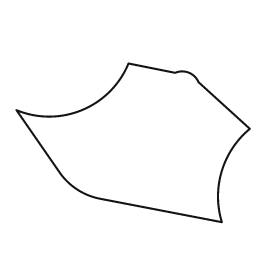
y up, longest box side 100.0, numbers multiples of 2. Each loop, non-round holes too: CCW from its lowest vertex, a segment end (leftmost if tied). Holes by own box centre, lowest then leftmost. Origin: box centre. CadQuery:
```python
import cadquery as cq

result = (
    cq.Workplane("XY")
    .moveTo(38.0, -34.0)
    .threePointArc((38.0, -12.0), (50.0, 6.0))
    .lineTo(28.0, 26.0)
    .threePointArc((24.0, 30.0), (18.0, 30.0))
    .lineTo(-2.0, 34.0)
    .threePointArc((-22.0, 14.0), (-50.0, 14.0))
    .lineTo(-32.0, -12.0)
    .threePointArc((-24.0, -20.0), (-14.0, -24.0))
    .close()
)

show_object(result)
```